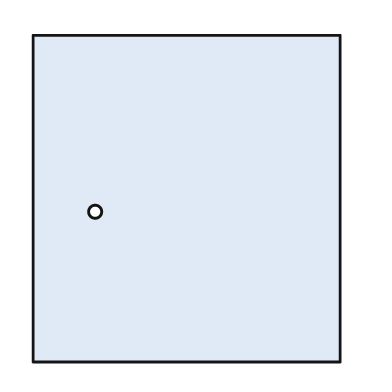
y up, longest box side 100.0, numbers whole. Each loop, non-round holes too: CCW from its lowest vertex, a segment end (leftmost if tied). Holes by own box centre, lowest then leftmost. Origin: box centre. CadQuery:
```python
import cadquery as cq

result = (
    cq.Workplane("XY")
    .moveTo(-47.0, -50.0)
    .lineTo(47.0, -50.0)
    .lineTo(47.0, 50.0)
    .lineTo(-47.0, 50.0)
    .close()
    .moveTo(-28.0, -4.0)
    .circle(2.0)
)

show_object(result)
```